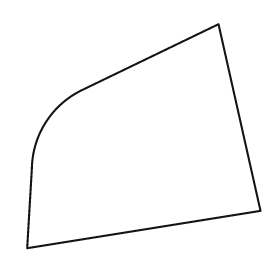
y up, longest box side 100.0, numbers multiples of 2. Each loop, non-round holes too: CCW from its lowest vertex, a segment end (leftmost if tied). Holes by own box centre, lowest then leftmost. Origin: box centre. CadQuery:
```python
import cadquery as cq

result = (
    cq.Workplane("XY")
    .moveTo(-50.0, -48.0)
    .lineTo(50.0, -32.0)
    .lineTo(32.0, 48.0)
    .lineTo(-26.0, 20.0)
    .threePointArc((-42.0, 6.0), (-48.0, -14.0))
    .close()
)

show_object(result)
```